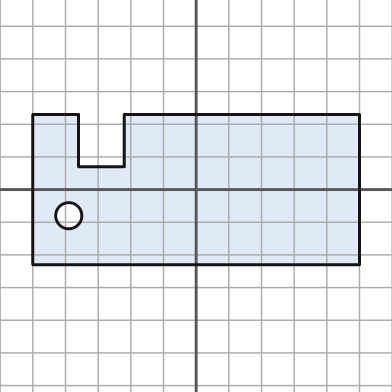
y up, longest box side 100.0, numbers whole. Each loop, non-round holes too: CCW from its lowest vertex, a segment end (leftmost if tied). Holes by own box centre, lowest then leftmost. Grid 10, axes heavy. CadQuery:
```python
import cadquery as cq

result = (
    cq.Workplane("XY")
    .moveTo(-50.0, -23.0)
    .lineTo(50.0, -23.0)
    .lineTo(50.0, 23.0)
    .lineTo(-22.0, 23.0)
    .lineTo(-22.0, 7.0)
    .lineTo(-36.0, 7.0)
    .lineTo(-36.0, 23.0)
    .lineTo(-50.0, 23.0)
    .close()
    .moveTo(-39.0, -8.0)
    .circle(4.0)
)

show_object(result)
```